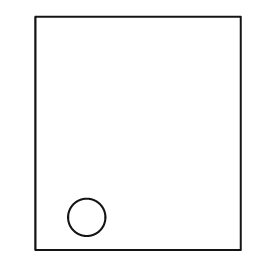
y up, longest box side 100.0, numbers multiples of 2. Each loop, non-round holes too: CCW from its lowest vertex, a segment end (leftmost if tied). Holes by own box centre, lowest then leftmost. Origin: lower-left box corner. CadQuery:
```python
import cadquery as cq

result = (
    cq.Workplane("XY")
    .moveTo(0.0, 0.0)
    .lineTo(88.0, 0.0)
    .lineTo(88.0, 100.0)
    .lineTo(0.0, 100.0)
    .close()
    .moveTo(22.0, 14.0)
    .circle(8.0)
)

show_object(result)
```